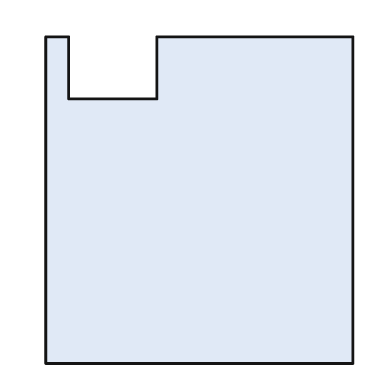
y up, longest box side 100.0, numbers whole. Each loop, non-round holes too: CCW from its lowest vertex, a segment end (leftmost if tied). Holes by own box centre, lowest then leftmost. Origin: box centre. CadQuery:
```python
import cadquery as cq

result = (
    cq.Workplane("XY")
    .moveTo(-47.0, -50.0)
    .lineTo(47.0, -50.0)
    .lineTo(47.0, 50.0)
    .lineTo(-13.0, 50.0)
    .lineTo(-13.0, 31.0)
    .lineTo(-40.0, 31.0)
    .lineTo(-40.0, 50.0)
    .lineTo(-47.0, 50.0)
    .close()
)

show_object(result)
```